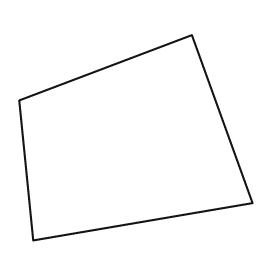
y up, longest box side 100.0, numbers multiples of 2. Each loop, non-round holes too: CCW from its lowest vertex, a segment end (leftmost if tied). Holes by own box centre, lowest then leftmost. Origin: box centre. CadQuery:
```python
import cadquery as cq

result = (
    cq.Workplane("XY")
    .moveTo(-44.0, -44.0)
    .lineTo(50.0, -28.0)
    .lineTo(24.0, 44.0)
    .lineTo(-50.0, 16.0)
    .close()
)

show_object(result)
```